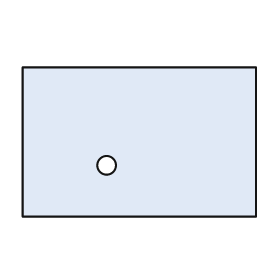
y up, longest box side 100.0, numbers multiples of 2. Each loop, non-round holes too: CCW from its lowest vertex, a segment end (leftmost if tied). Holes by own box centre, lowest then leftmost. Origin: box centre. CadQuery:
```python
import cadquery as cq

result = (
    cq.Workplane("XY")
    .moveTo(-50.0, -32.0)
    .lineTo(50.0, -32.0)
    .lineTo(50.0, 32.0)
    .lineTo(-50.0, 32.0)
    .close()
    .moveTo(-14.0, -10.0)
    .circle(4.0)
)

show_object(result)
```